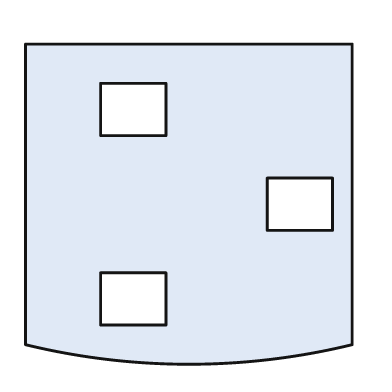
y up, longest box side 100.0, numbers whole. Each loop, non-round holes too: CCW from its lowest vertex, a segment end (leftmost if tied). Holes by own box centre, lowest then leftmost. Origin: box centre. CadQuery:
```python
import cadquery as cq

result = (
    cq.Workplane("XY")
    .moveTo(-50.0, -43.0)
    .threePointArc((0.0, -49.0), (50.0, -43.0))
    .lineTo(50.0, 49.0)
    .lineTo(-50.0, 49.0)
    .close()
    .moveTo(-27.0, -37.0)
    .lineTo(-7.0, -37.0)
    .lineTo(-7.0, -21.0)
    .lineTo(-27.0, -21.0)
    .close()
    .moveTo(24.0, -8.0)
    .lineTo(44.0, -8.0)
    .lineTo(44.0, 8.0)
    .lineTo(24.0, 8.0)
    .close()
    .moveTo(-27.0, 21.0)
    .lineTo(-7.0, 21.0)
    .lineTo(-7.0, 37.0)
    .lineTo(-27.0, 37.0)
    .close()
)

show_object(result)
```